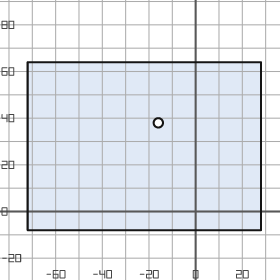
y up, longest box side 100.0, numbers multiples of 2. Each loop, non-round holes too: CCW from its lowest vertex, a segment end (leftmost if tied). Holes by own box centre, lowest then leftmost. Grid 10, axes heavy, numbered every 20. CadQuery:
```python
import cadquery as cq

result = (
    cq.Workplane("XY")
    .moveTo(-72.0, -8.0)
    .lineTo(28.0, -8.0)
    .lineTo(28.0, 64.0)
    .lineTo(-72.0, 64.0)
    .close()
    .moveTo(-16.0, 38.0)
    .circle(2.0)
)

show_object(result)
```